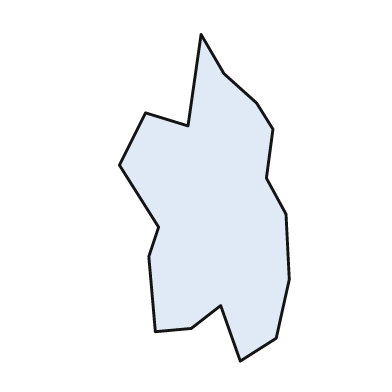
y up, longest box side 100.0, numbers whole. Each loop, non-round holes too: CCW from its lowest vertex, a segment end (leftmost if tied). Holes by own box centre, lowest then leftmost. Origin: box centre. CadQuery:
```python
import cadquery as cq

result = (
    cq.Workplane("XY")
    .moveTo(11.0, -50.0)
    .lineTo(22.0, -43.0)
    .lineTo(26.0, -25.0)
    .lineTo(25.0, -5.0)
    .lineTo(19.0, 6.0)
    .lineTo(21.0, 21.0)
    .lineTo(16.0, 29.0)
    .lineTo(6.0, 38.0)
    .lineTo(-1.0, 50.0)
    .lineTo(-5.0, 22.0)
    .lineTo(-18.0, 26.0)
    .lineTo(-26.0, 10.0)
    .lineTo(-14.0, -9.0)
    .lineTo(-17.0, -18.0)
    .lineTo(-15.0, -41.0)
    .lineTo(-4.0, -40.0)
    .lineTo(5.0, -33.0)
    .close()
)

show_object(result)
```